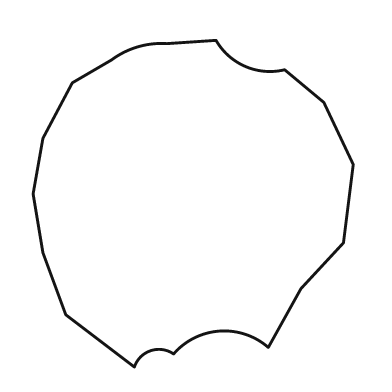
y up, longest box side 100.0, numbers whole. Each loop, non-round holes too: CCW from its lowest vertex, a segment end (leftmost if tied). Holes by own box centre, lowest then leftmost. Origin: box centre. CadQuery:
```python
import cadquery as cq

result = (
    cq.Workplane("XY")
    .moveTo(-18.0, -50.0)
    .threePointArc((-13.0, -45.0), (-6.0, -46.0))
    .threePointArc((8.0, -39.0), (23.0, -44.0))
    .lineTo(33.0, -26.0)
    .lineTo(46.0, -12.0)
    .lineTo(49.0, 12.0)
    .lineTo(40.0, 31.0)
    .lineTo(28.0, 41.0)
    .threePointArc((16.0, 42.0), (7.0, 50.0))
    .lineTo(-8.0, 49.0)
    .threePointArc((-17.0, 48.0), (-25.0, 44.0))
    .lineTo(-37.0, 37.0)
    .lineTo(-46.0, 20.0)
    .lineTo(-49.0, 3.0)
    .lineTo(-46.0, -15.0)
    .lineTo(-39.0, -34.0)
    .close()
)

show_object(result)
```